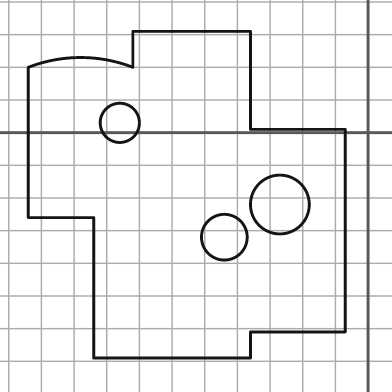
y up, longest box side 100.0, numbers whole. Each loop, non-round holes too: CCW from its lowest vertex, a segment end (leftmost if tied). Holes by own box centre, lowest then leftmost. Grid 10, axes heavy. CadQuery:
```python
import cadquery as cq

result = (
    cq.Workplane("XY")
    .moveTo(-84.0, -69.0)
    .lineTo(-36.0, -69.0)
    .lineTo(-36.0, -61.0)
    .lineTo(-7.0, -61.0)
    .lineTo(-7.0, 1.0)
    .lineTo(-36.0, 1.0)
    .lineTo(-36.0, 31.0)
    .lineTo(-72.0, 31.0)
    .lineTo(-72.0, 20.0)
    .threePointArc((-88.0, 23.0), (-104.0, 20.0))
    .lineTo(-104.0, -26.0)
    .lineTo(-84.0, -26.0)
    .close()
    .moveTo(-44.0, -32.0)
    .circle(7.0)
    .moveTo(-27.0, -22.0)
    .circle(9.0)
    .moveTo(-76.0, 3.0)
    .circle(6.0)
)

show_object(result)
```